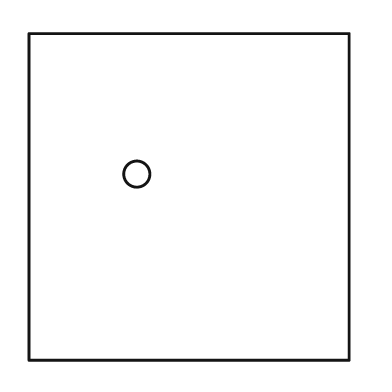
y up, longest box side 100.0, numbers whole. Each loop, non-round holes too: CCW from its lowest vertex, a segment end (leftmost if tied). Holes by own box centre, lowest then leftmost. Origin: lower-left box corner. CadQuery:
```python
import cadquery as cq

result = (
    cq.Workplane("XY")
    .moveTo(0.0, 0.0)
    .lineTo(98.0, 0.0)
    .lineTo(98.0, 100.0)
    .lineTo(0.0, 100.0)
    .close()
    .moveTo(33.0, 57.0)
    .circle(4.0)
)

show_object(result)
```